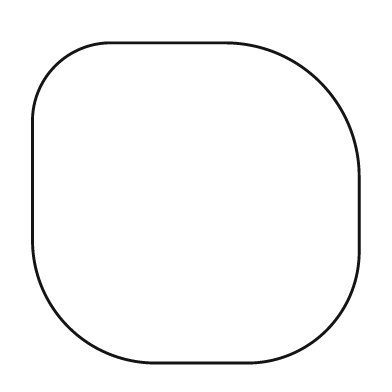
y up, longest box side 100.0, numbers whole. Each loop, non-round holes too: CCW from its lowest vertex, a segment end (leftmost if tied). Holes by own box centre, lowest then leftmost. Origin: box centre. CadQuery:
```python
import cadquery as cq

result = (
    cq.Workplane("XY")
    .moveTo(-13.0, -49.0)
    .lineTo(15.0, -49.0)
    .threePointArc((40.0, -39.0), (50.0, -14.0))
    .lineTo(50.0, 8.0)
    .threePointArc((38.0, 37.0), (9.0, 49.0))
    .lineTo(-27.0, 49.0)
    .threePointArc((-43.0, 42.0), (-50.0, 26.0))
    .lineTo(-50.0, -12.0)
    .threePointArc((-39.0, -38.0), (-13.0, -49.0))
    .close()
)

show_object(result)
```